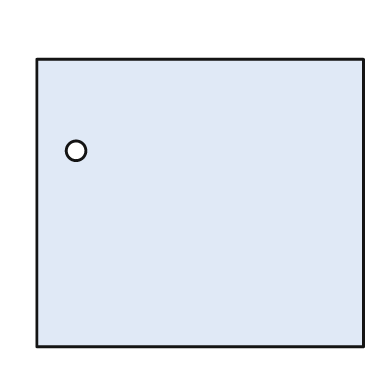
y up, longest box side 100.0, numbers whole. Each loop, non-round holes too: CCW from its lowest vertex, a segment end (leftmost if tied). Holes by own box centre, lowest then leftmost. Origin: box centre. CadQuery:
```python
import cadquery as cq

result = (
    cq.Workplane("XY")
    .moveTo(-50.0, -44.0)
    .lineTo(50.0, -44.0)
    .lineTo(50.0, 44.0)
    .lineTo(-50.0, 44.0)
    .close()
    .moveTo(-38.0, 16.0)
    .circle(3.0)
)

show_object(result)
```